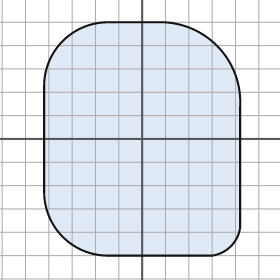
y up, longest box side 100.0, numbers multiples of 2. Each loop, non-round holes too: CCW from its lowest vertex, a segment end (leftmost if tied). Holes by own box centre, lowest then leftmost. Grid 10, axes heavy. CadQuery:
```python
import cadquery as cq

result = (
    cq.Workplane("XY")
    .moveTo(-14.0, -50.0)
    .lineTo(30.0, -50.0)
    .threePointArc((38.0, -46.0), (42.0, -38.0))
    .lineTo(42.0, 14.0)
    .threePointArc((32.0, 40.0), (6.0, 50.0))
    .lineTo(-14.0, 50.0)
    .threePointArc((-34.0, 42.0), (-42.0, 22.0))
    .lineTo(-42.0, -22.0)
    .threePointArc((-34.0, -42.0), (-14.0, -50.0))
    .close()
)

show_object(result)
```